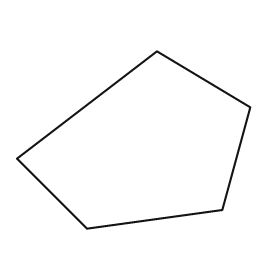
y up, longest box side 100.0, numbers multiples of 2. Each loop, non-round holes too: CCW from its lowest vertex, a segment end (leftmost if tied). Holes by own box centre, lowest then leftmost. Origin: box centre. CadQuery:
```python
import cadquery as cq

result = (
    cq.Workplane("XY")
    .moveTo(-20.0, -38.0)
    .lineTo(38.0, -30.0)
    .lineTo(50.0, 14.0)
    .lineTo(10.0, 38.0)
    .lineTo(-50.0, -8.0)
    .close()
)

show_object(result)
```